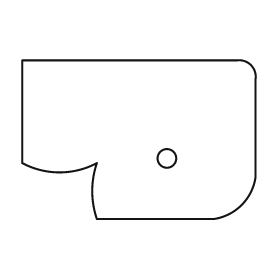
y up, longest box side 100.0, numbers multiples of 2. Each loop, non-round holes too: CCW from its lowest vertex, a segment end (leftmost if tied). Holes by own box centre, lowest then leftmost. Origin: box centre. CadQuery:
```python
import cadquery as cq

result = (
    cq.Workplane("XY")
    .moveTo(-18.0, -34.0)
    .lineTo(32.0, -34.0)
    .threePointArc((44.0, -28.0), (50.0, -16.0))
    .lineTo(50.0, 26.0)
    .threePointArc((48.0, 32.0), (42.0, 34.0))
    .lineTo(-50.0, 34.0)
    .lineTo(-50.0, -10.0)
    .threePointArc((-34.0, -14.0), (-18.0, -10.0))
    .threePointArc((-20.0, -22.0), (-18.0, -34.0))
    .close()
    .moveTo(12.0, -8.0)
    .circle(4.0)
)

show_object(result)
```